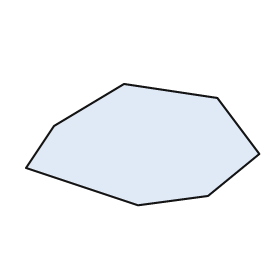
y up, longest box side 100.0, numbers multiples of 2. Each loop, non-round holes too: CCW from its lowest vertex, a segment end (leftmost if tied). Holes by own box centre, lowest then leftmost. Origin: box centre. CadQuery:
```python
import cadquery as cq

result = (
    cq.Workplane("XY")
    .moveTo(-2.0, -26.0)
    .lineTo(28.0, -22.0)
    .lineTo(50.0, -4.0)
    .lineTo(32.0, 20.0)
    .lineTo(-8.0, 26.0)
    .lineTo(-38.0, 8.0)
    .lineTo(-50.0, -10.0)
    .close()
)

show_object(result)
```